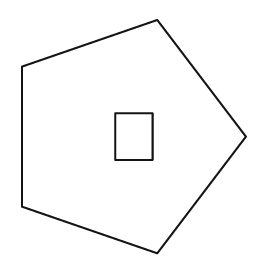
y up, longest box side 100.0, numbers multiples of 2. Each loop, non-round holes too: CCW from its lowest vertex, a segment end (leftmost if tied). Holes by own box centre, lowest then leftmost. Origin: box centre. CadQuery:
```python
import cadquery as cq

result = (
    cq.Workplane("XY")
    .moveTo(10.0, -50.0)
    .lineTo(48.0, 0.0)
    .lineTo(10.0, 50.0)
    .lineTo(-48.0, 30.0)
    .lineTo(-48.0, -30.0)
    .close()
    .moveTo(-8.0, -10.0)
    .lineTo(8.0, -10.0)
    .lineTo(8.0, 10.0)
    .lineTo(-8.0, 10.0)
    .close()
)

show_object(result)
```